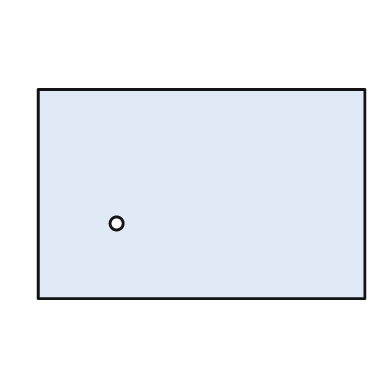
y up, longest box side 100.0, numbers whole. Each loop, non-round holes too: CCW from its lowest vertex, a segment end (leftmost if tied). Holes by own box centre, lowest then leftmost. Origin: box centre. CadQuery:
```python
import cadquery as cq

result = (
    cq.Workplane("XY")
    .moveTo(-50.0, -32.0)
    .lineTo(50.0, -32.0)
    .lineTo(50.0, 32.0)
    .lineTo(-50.0, 32.0)
    .close()
    .moveTo(-26.0, -9.0)
    .circle(2.0)
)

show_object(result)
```